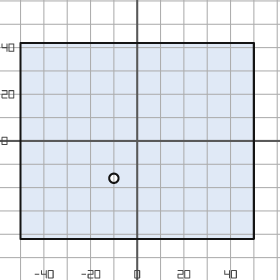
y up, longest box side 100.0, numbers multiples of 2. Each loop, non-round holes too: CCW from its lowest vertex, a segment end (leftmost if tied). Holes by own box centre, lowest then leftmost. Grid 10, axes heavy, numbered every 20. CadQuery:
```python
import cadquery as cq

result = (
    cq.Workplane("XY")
    .moveTo(-50.0, -42.0)
    .lineTo(50.0, -42.0)
    .lineTo(50.0, 42.0)
    .lineTo(-50.0, 42.0)
    .close()
    .moveTo(-10.0, -16.0)
    .circle(2.0)
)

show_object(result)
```